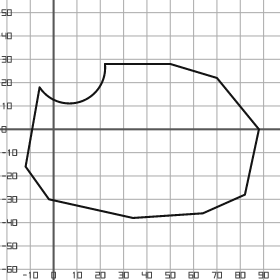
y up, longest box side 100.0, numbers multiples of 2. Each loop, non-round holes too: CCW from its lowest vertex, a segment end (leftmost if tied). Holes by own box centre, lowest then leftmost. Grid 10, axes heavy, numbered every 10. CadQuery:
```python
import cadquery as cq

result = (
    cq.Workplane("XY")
    .moveTo(34.0, -38.0)
    .lineTo(64.0, -36.0)
    .lineTo(82.0, -28.0)
    .lineTo(88.0, 0.0)
    .lineTo(70.0, 22.0)
    .lineTo(50.0, 28.0)
    .lineTo(22.0, 28.0)
    .threePointArc((12.0, 12.0), (-6.0, 18.0))
    .lineTo(-12.0, -16.0)
    .lineTo(-2.0, -30.0)
    .close()
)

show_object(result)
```